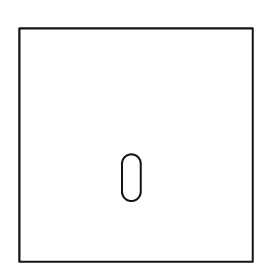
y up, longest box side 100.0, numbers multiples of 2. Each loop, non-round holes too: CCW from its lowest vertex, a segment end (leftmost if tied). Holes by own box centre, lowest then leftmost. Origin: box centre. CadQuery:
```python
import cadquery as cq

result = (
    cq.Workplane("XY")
    .moveTo(-50.0, -50.0)
    .lineTo(50.0, -50.0)
    .lineTo(50.0, 50.0)
    .lineTo(-50.0, 50.0)
    .close()
    .moveTo(-6.0, -20.0)
    .threePointArc((-2.0, -24.0), (2.0, -20.0))
    .lineTo(2.0, -8.0)
    .threePointArc((-2.0, -4.0), (-6.0, -8.0))
    .close()
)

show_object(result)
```